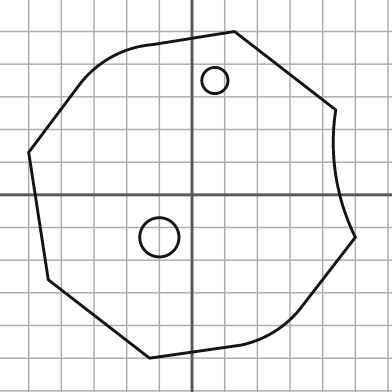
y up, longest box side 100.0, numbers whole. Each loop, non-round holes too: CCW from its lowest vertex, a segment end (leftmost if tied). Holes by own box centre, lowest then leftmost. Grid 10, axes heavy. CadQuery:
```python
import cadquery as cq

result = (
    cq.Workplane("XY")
    .moveTo(-13.0, -50.0)
    .lineTo(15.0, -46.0)
    .threePointArc((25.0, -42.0), (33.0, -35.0))
    .lineTo(50.0, -13.0)
    .threePointArc((44.0, 6.0), (44.0, 26.0))
    .lineTo(13.0, 50.0)
    .lineTo(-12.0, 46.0)
    .threePointArc((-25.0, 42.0), (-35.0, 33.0))
    .lineTo(-50.0, 13.0)
    .lineTo(-44.0, -26.0)
    .close()
    .moveTo(-10.0, -13.0)
    .circle(6.0)
    .moveTo(7.0, 35.0)
    .circle(4.0)
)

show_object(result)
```